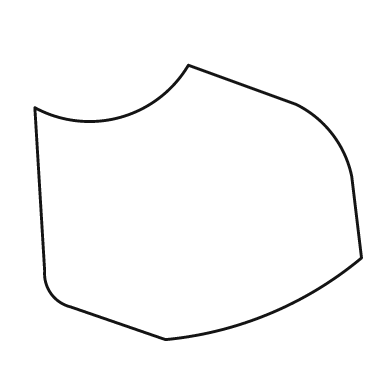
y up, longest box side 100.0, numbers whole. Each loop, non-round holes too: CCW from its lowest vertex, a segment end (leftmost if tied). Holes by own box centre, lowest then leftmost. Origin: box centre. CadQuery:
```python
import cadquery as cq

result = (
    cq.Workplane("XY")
    .moveTo(-10.0, -42.0)
    .threePointArc((22.0, -34.0), (50.0, -17.0))
    .lineTo(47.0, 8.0)
    .threePointArc((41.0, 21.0), (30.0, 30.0))
    .lineTo(-3.0, 42.0)
    .threePointArc((-24.0, 26.0), (-50.0, 29.0))
    .lineTo(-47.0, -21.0)
    .threePointArc((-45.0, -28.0), (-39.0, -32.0))
    .close()
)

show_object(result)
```